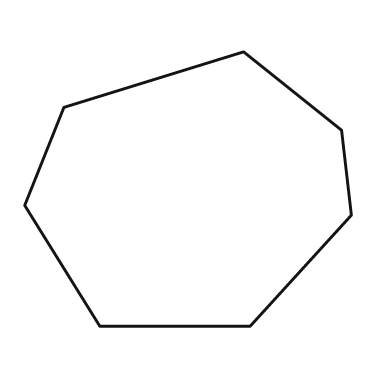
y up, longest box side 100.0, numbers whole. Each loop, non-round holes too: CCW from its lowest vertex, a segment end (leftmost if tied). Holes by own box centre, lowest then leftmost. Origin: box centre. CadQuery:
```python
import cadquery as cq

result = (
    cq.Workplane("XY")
    .moveTo(-27.0, -42.0)
    .lineTo(19.0, -42.0)
    .lineTo(50.0, -8.0)
    .lineTo(47.0, 18.0)
    .lineTo(17.0, 42.0)
    .lineTo(-38.0, 25.0)
    .lineTo(-50.0, -5.0)
    .close()
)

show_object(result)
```